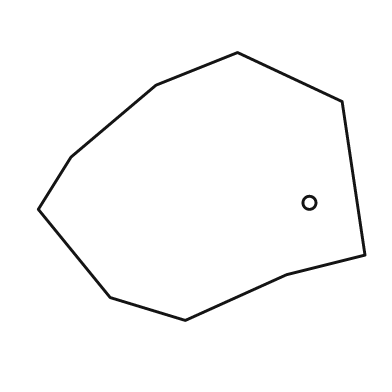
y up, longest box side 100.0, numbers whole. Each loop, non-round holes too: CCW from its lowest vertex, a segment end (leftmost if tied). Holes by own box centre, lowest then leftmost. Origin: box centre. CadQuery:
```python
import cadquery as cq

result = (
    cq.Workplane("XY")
    .moveTo(-5.0, -41.0)
    .lineTo(26.0, -27.0)
    .lineTo(50.0, -21.0)
    .lineTo(43.0, 26.0)
    .lineTo(11.0, 41.0)
    .lineTo(-14.0, 31.0)
    .lineTo(-40.0, 9.0)
    .lineTo(-50.0, -7.0)
    .lineTo(-28.0, -34.0)
    .close()
    .moveTo(33.0, -5.0)
    .circle(2.0)
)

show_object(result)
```